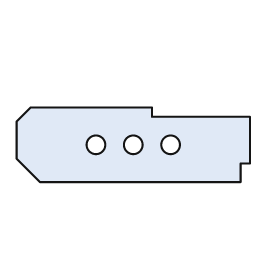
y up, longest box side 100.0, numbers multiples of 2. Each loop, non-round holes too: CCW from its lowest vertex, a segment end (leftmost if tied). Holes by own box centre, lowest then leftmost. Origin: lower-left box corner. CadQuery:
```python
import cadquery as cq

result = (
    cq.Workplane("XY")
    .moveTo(10.0, 0.0)
    .lineTo(96.0, 0.0)
    .lineTo(96.0, 8.0)
    .lineTo(100.0, 8.0)
    .lineTo(100.0, 28.0)
    .lineTo(58.0, 28.0)
    .lineTo(58.0, 32.0)
    .lineTo(6.0, 32.0)
    .lineTo(0.0, 26.0)
    .lineTo(0.0, 10.0)
    .close()
    .moveTo(34.0, 16.0)
    .circle(4.0)
    .moveTo(50.0, 16.0)
    .circle(4.0)
    .moveTo(66.0, 16.0)
    .circle(4.0)
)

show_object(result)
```